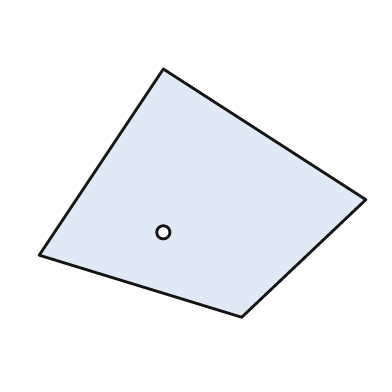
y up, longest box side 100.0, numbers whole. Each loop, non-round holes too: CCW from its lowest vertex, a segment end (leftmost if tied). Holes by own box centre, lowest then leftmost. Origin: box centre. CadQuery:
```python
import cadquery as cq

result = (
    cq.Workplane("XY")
    .moveTo(12.0, -38.0)
    .lineTo(50.0, -2.0)
    .lineTo(-12.0, 38.0)
    .lineTo(-50.0, -19.0)
    .close()
    .moveTo(-12.0, -12.0)
    .circle(2.0)
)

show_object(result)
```